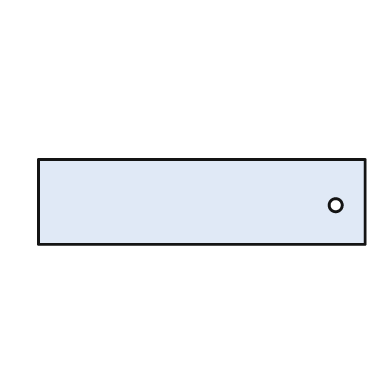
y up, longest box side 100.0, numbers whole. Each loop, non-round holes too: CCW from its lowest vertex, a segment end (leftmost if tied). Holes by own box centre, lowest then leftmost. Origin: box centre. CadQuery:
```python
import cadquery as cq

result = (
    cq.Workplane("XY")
    .moveTo(-50.0, -13.0)
    .lineTo(50.0, -13.0)
    .lineTo(50.0, 13.0)
    .lineTo(-50.0, 13.0)
    .close()
    .moveTo(41.0, -1.0)
    .circle(2.0)
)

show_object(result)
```